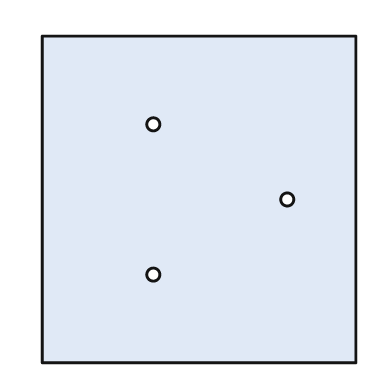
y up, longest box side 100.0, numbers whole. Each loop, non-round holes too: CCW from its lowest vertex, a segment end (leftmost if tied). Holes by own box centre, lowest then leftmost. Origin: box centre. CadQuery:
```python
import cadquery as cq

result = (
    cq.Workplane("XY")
    .moveTo(-48.0, -50.0)
    .lineTo(48.0, -50.0)
    .lineTo(48.0, 50.0)
    .lineTo(-48.0, 50.0)
    .close()
    .moveTo(-14.0, -23.0)
    .circle(2.0)
    .moveTo(27.0, 0.0)
    .circle(2.0)
    .moveTo(-14.0, 23.0)
    .circle(2.0)
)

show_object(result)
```